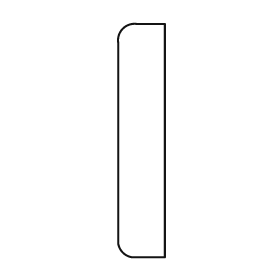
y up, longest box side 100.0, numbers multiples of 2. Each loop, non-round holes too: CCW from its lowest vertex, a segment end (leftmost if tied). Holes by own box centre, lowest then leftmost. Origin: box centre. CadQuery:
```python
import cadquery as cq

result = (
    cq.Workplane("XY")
    .moveTo(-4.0, -50.0)
    .lineTo(10.0, -50.0)
    .lineTo(10.0, 50.0)
    .lineTo(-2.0, 50.0)
    .threePointArc((-8.0, 48.0), (-10.0, 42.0))
    .lineTo(-10.0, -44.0)
    .threePointArc((-8.0, -48.0), (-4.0, -50.0))
    .close()
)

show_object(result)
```